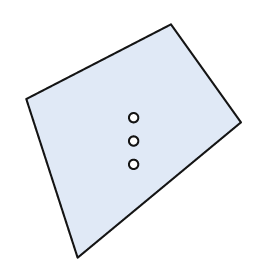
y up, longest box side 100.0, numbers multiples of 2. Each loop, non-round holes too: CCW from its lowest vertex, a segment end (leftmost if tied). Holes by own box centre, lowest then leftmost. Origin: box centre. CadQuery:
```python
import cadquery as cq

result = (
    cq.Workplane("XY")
    .moveTo(-24.0, -50.0)
    .lineTo(46.0, 8.0)
    .lineTo(16.0, 50.0)
    .lineTo(-46.0, 18.0)
    .close()
    .moveTo(0.0, -10.0)
    .circle(2.0)
    .moveTo(0.0, 0.0)
    .circle(2.0)
    .moveTo(0.0, 10.0)
    .circle(2.0)
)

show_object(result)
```